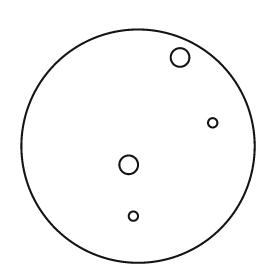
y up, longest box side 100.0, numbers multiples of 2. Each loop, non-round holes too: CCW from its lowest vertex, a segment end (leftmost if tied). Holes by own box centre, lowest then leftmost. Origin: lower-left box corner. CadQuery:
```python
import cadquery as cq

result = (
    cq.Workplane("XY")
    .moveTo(50.0, 50.0)
    .circle(50.0)
    .moveTo(48.0, 20.0)
    .circle(2.0)
    .moveTo(46.0, 42.0)
    .circle(4.0)
    .moveTo(82.0, 60.0)
    .circle(2.0)
    .moveTo(68.0, 88.0)
    .circle(4.0)
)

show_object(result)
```